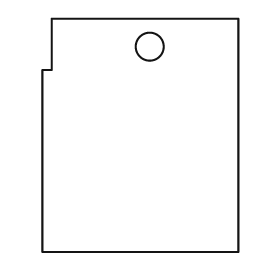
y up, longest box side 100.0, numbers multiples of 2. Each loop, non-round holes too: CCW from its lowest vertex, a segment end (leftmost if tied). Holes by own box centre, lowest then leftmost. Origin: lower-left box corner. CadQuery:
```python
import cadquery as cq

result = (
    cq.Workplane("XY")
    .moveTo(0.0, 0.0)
    .lineTo(84.0, 0.0)
    .lineTo(84.0, 100.0)
    .lineTo(4.0, 100.0)
    .lineTo(4.0, 78.0)
    .lineTo(0.0, 78.0)
    .close()
    .moveTo(46.0, 88.0)
    .circle(6.0)
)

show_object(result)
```